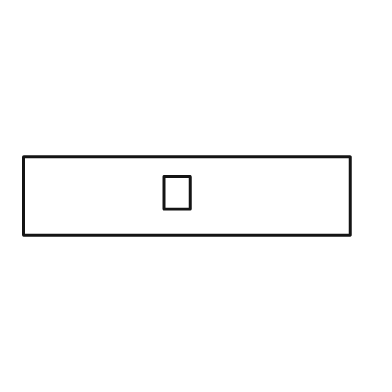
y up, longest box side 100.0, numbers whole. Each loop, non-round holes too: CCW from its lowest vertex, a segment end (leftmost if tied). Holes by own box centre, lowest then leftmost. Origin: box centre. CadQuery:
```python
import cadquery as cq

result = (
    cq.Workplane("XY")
    .moveTo(-50.0, -12.0)
    .lineTo(50.0, -12.0)
    .lineTo(50.0, 12.0)
    .lineTo(-50.0, 12.0)
    .close()
    .moveTo(-7.0, -4.0)
    .lineTo(1.0, -4.0)
    .lineTo(1.0, 6.0)
    .lineTo(-7.0, 6.0)
    .close()
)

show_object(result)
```